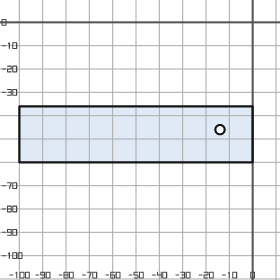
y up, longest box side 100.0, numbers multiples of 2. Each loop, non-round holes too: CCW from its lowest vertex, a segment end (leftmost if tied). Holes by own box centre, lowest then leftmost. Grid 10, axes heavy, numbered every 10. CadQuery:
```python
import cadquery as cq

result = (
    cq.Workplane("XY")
    .moveTo(-100.0, -60.0)
    .lineTo(0.0, -60.0)
    .lineTo(0.0, -36.0)
    .lineTo(-100.0, -36.0)
    .close()
    .moveTo(-14.0, -46.0)
    .circle(2.0)
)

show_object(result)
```